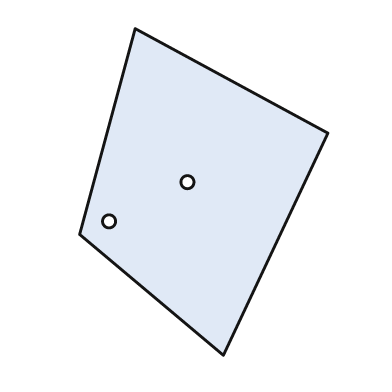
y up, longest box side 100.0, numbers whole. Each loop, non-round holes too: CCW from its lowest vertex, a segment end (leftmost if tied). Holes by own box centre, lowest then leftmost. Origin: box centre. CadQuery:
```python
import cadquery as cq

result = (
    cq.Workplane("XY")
    .moveTo(6.0, -50.0)
    .lineTo(38.0, 18.0)
    .lineTo(-21.0, 50.0)
    .lineTo(-38.0, -13.0)
    .close()
    .moveTo(-29.0, -9.0)
    .circle(2.0)
    .moveTo(-5.0, 3.0)
    .circle(2.0)
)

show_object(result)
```